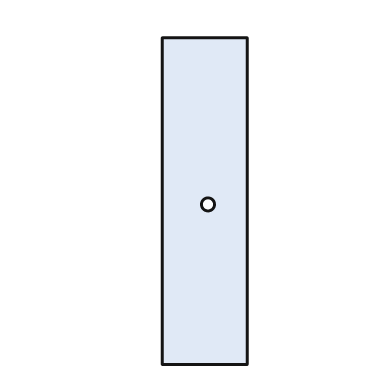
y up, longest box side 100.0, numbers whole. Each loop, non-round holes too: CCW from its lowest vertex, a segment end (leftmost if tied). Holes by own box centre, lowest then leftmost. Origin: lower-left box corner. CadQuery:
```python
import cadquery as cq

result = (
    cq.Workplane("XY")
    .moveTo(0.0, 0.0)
    .lineTo(26.0, 0.0)
    .lineTo(26.0, 100.0)
    .lineTo(0.0, 100.0)
    .close()
    .moveTo(14.0, 49.0)
    .circle(2.0)
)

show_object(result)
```